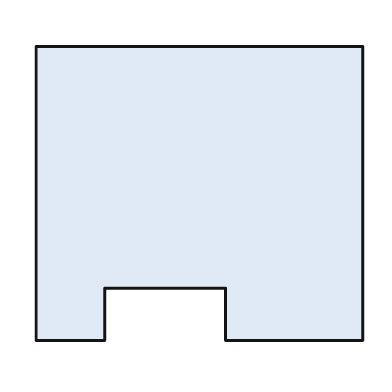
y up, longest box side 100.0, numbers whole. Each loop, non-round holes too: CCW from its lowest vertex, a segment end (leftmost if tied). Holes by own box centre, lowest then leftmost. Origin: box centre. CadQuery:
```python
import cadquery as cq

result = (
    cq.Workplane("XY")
    .moveTo(-50.0, -45.0)
    .lineTo(-29.0, -45.0)
    .lineTo(-29.0, -29.0)
    .lineTo(8.0, -29.0)
    .lineTo(8.0, -45.0)
    .lineTo(50.0, -45.0)
    .lineTo(50.0, 45.0)
    .lineTo(-50.0, 45.0)
    .close()
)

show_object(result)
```